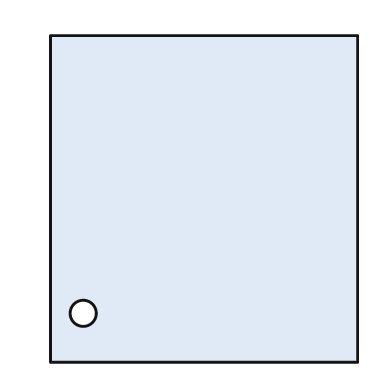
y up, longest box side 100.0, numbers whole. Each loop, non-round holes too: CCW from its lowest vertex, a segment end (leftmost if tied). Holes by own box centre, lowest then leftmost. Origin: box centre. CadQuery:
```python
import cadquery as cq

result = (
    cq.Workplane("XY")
    .moveTo(-47.0, -50.0)
    .lineTo(47.0, -50.0)
    .lineTo(47.0, 50.0)
    .lineTo(-47.0, 50.0)
    .close()
    .moveTo(-37.0, -35.0)
    .circle(4.0)
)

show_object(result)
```